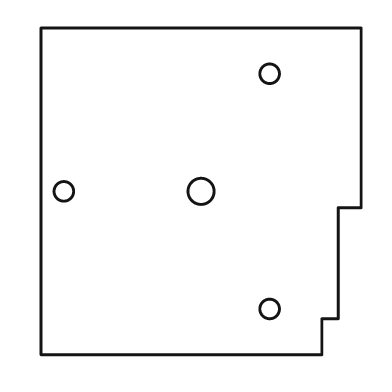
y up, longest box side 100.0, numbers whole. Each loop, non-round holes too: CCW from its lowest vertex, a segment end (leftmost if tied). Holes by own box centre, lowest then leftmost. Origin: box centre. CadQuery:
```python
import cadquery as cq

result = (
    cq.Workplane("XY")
    .moveTo(-49.0, -50.0)
    .lineTo(37.0, -50.0)
    .lineTo(37.0, -39.0)
    .lineTo(42.0, -39.0)
    .lineTo(42.0, -5.0)
    .lineTo(49.0, -5.0)
    .lineTo(49.0, 50.0)
    .lineTo(-49.0, 50.0)
    .close()
    .moveTo(21.0, -36.0)
    .circle(3.0)
    .moveTo(-42.0, 0.0)
    .circle(3.0)
    .moveTo(0.0, 0.0)
    .circle(4.0)
    .moveTo(21.0, 36.0)
    .circle(3.0)
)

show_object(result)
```